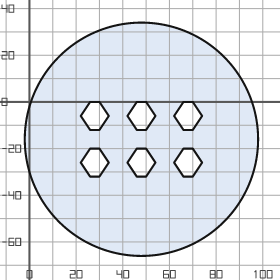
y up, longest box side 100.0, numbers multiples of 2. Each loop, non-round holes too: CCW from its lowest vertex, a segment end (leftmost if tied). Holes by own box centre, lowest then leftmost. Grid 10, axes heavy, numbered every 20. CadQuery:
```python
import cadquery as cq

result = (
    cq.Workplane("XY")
    .moveTo(48.0, -16.0)
    .circle(50.0)
    .moveTo(26.0, -32.0)
    .lineTo(30.0, -32.0)
    .lineTo(34.0, -26.0)
    .lineTo(30.0, -20.0)
    .lineTo(26.0, -20.0)
    .lineTo(22.0, -26.0)
    .close()
    .moveTo(46.0, -32.0)
    .lineTo(50.0, -32.0)
    .lineTo(54.0, -26.0)
    .lineTo(50.0, -20.0)
    .lineTo(46.0, -20.0)
    .lineTo(42.0, -26.0)
    .close()
    .moveTo(66.0, -32.0)
    .lineTo(70.0, -32.0)
    .lineTo(74.0, -26.0)
    .lineTo(70.0, -20.0)
    .lineTo(66.0, -20.0)
    .lineTo(62.0, -26.0)
    .close()
    .moveTo(26.0, -12.0)
    .lineTo(30.0, -12.0)
    .lineTo(34.0, -6.0)
    .lineTo(30.0, 0.0)
    .lineTo(26.0, 0.0)
    .lineTo(22.0, -6.0)
    .close()
    .moveTo(46.0, -12.0)
    .lineTo(50.0, -12.0)
    .lineTo(54.0, -6.0)
    .lineTo(50.0, 0.0)
    .lineTo(46.0, 0.0)
    .lineTo(42.0, -6.0)
    .close()
    .moveTo(66.0, -12.0)
    .lineTo(70.0, -12.0)
    .lineTo(74.0, -6.0)
    .lineTo(70.0, 0.0)
    .lineTo(66.0, 0.0)
    .lineTo(62.0, -6.0)
    .close()
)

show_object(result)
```